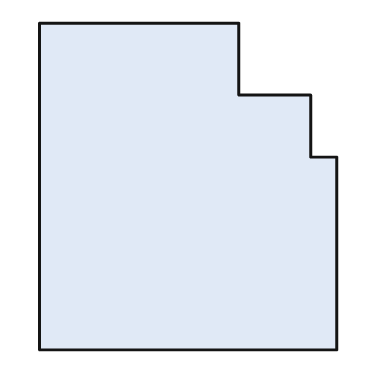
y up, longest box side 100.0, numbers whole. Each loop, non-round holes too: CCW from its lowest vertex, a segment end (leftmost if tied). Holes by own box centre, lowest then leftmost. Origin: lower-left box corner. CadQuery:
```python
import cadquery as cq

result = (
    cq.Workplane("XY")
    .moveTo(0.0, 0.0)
    .lineTo(91.0, 0.0)
    .lineTo(91.0, 59.0)
    .lineTo(83.0, 59.0)
    .lineTo(83.0, 78.0)
    .lineTo(61.0, 78.0)
    .lineTo(61.0, 100.0)
    .lineTo(0.0, 100.0)
    .close()
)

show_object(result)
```